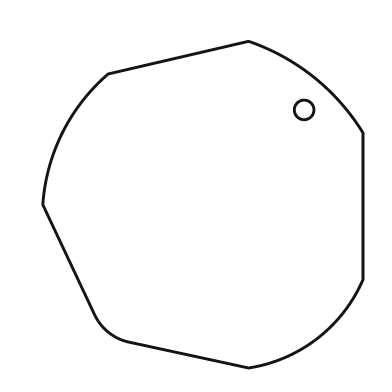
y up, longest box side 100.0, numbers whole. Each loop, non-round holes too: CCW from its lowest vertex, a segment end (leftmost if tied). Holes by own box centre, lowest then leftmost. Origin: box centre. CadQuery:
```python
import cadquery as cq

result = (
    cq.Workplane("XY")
    .moveTo(14.0, -50.0)
    .threePointArc((35.0, -41.0), (49.0, -23.0))
    .lineTo(49.0, 22.0)
    .threePointArc((34.0, 39.0), (14.0, 50.0))
    .lineTo(-29.0, 40.0)
    .threePointArc((-43.0, 22.0), (-49.0, 0.0))
    .lineTo(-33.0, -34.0)
    .threePointArc((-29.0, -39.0), (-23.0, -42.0))
    .close()
    .moveTo(31.0, 29.0)
    .circle(3.0)
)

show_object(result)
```